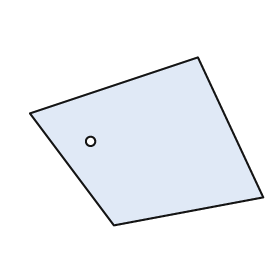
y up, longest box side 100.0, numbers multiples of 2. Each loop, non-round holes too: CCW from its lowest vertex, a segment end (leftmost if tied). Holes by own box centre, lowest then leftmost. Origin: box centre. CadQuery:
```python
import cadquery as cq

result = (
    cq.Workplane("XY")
    .moveTo(-14.0, -36.0)
    .lineTo(50.0, -24.0)
    .lineTo(22.0, 36.0)
    .lineTo(-50.0, 12.0)
    .close()
    .moveTo(-24.0, 0.0)
    .circle(2.0)
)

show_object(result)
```